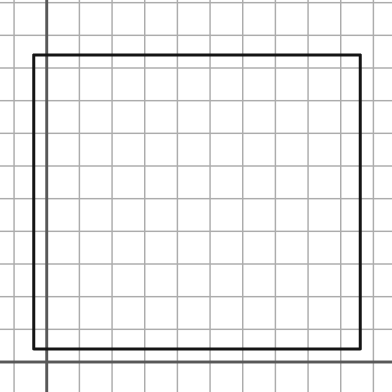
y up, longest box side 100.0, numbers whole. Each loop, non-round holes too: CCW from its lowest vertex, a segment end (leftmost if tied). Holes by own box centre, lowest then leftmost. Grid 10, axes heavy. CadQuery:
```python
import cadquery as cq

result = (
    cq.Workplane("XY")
    .moveTo(-4.0, 4.0)
    .lineTo(96.0, 4.0)
    .lineTo(96.0, 94.0)
    .lineTo(-4.0, 94.0)
    .close()
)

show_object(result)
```